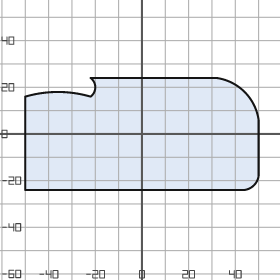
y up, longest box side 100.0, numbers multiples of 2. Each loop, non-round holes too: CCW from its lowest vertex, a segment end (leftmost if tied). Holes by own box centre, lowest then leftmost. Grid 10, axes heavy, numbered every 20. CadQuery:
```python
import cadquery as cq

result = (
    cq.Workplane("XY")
    .moveTo(-50.0, -24.0)
    .lineTo(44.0, -24.0)
    .threePointArc((48.0, -22.0), (50.0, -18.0))
    .lineTo(50.0, 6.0)
    .threePointArc((44.0, 18.0), (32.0, 24.0))
    .lineTo(-22.0, 24.0)
    .threePointArc((-20.0, 20.0), (-22.0, 16.0))
    .threePointArc((-36.0, 18.0), (-50.0, 16.0))
    .close()
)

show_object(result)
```